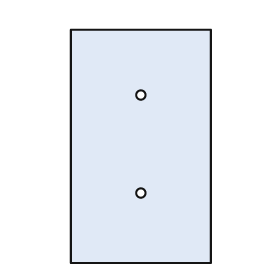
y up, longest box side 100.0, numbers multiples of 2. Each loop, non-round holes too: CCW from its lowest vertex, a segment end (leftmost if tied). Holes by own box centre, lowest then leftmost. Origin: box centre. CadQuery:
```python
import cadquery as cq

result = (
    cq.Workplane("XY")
    .moveTo(-30.0, -50.0)
    .lineTo(30.0, -50.0)
    .lineTo(30.0, 50.0)
    .lineTo(-30.0, 50.0)
    .close()
    .moveTo(0.0, -20.0)
    .circle(2.0)
    .moveTo(0.0, 22.0)
    .circle(2.0)
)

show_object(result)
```